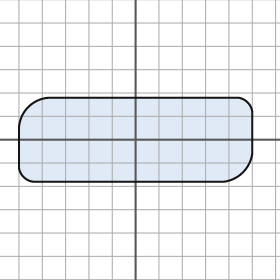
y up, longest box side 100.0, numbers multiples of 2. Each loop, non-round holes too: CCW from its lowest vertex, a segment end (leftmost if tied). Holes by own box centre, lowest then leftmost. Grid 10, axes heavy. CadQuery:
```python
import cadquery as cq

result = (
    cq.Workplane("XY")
    .moveTo(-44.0, -18.0)
    .lineTo(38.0, -18.0)
    .threePointArc((46.0, -14.0), (50.0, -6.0))
    .lineTo(50.0, 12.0)
    .threePointArc((48.0, 16.0), (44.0, 18.0))
    .lineTo(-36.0, 18.0)
    .threePointArc((-46.0, 14.0), (-50.0, 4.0))
    .lineTo(-50.0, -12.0)
    .threePointArc((-48.0, -16.0), (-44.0, -18.0))
    .close()
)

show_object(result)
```